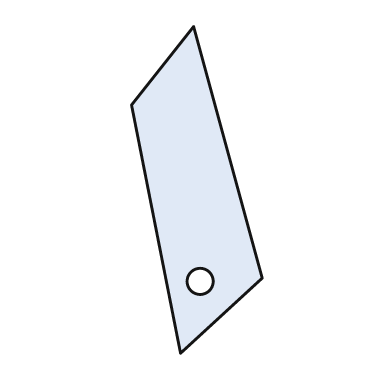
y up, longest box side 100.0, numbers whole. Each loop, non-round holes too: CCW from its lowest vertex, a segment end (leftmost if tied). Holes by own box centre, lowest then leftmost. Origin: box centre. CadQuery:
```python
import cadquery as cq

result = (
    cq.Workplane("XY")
    .moveTo(-5.0, -50.0)
    .lineTo(20.0, -27.0)
    .lineTo(-1.0, 50.0)
    .lineTo(-20.0, 26.0)
    .close()
    .moveTo(1.0, -28.0)
    .circle(4.0)
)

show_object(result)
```